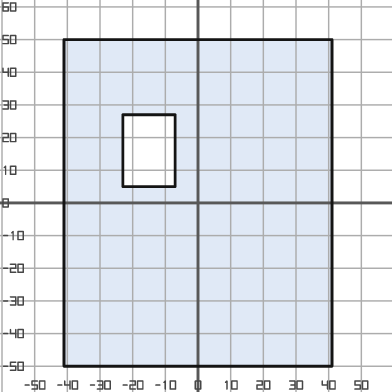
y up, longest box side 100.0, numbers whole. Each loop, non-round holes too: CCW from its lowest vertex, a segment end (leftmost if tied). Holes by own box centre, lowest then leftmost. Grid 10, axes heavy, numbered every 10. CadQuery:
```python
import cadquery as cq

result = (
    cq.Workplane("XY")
    .moveTo(-41.0, -50.0)
    .lineTo(41.0, -50.0)
    .lineTo(41.0, 50.0)
    .lineTo(-41.0, 50.0)
    .close()
    .moveTo(-23.0, 5.0)
    .lineTo(-7.0, 5.0)
    .lineTo(-7.0, 27.0)
    .lineTo(-23.0, 27.0)
    .close()
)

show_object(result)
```